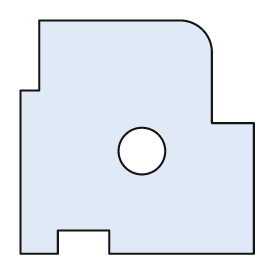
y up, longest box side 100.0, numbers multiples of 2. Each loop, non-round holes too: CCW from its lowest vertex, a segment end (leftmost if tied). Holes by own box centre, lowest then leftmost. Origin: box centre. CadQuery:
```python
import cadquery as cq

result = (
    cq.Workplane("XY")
    .moveTo(-50.0, -50.0)
    .lineTo(-34.0, -50.0)
    .lineTo(-34.0, -40.0)
    .lineTo(-12.0, -40.0)
    .lineTo(-12.0, -50.0)
    .lineTo(50.0, -50.0)
    .lineTo(50.0, 6.0)
    .lineTo(32.0, 6.0)
    .lineTo(32.0, 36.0)
    .threePointArc((28.0, 46.0), (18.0, 50.0))
    .lineTo(-42.0, 50.0)
    .lineTo(-42.0, 20.0)
    .lineTo(-50.0, 20.0)
    .close()
    .moveTo(2.0, -6.0)
    .circle(10.0)
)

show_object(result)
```